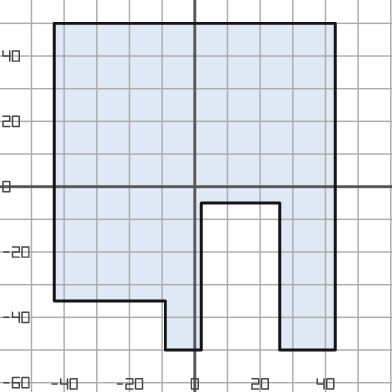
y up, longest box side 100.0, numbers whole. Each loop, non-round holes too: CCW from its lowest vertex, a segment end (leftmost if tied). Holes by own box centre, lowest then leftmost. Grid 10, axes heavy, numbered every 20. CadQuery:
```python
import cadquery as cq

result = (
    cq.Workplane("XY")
    .moveTo(-9.0, -50.0)
    .lineTo(2.0, -50.0)
    .lineTo(2.0, -5.0)
    .lineTo(26.0, -5.0)
    .lineTo(26.0, -50.0)
    .lineTo(43.0, -50.0)
    .lineTo(43.0, 50.0)
    .lineTo(-43.0, 50.0)
    .lineTo(-43.0, -35.0)
    .lineTo(-9.0, -35.0)
    .close()
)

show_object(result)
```